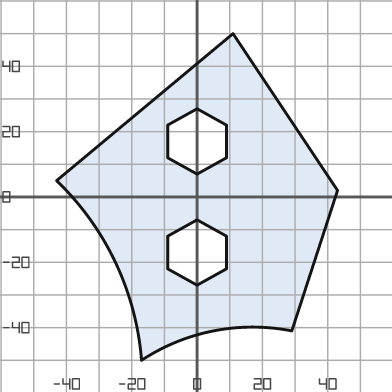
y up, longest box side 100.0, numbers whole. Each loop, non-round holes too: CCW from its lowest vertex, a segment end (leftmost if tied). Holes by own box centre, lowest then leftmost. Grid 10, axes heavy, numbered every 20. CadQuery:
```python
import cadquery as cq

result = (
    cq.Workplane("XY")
    .moveTo(-17.0, -50.0)
    .threePointArc((5.0, -41.0), (29.0, -41.0))
    .lineTo(43.0, 2.0)
    .lineTo(11.0, 50.0)
    .lineTo(-43.0, 5.0)
    .threePointArc((-25.0, -20.0), (-17.0, -50.0))
    .close()
    .moveTo(0.0, -27.0)
    .lineTo(9.0, -22.0)
    .lineTo(9.0, -12.0)
    .lineTo(0.0, -7.0)
    .lineTo(-9.0, -12.0)
    .lineTo(-9.0, -22.0)
    .close()
    .moveTo(0.0, 7.0)
    .lineTo(9.0, 12.0)
    .lineTo(9.0, 22.0)
    .lineTo(0.0, 27.0)
    .lineTo(-9.0, 22.0)
    .lineTo(-9.0, 12.0)
    .close()
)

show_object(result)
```